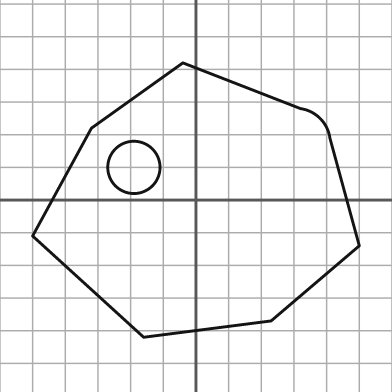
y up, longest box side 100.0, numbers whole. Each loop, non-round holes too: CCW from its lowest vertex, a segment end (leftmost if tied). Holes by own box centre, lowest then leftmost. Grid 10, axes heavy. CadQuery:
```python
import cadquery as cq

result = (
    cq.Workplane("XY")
    .moveTo(-16.0, -42.0)
    .lineTo(23.0, -37.0)
    .lineTo(50.0, -14.0)
    .lineTo(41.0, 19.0)
    .threePointArc((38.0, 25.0), (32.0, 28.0))
    .lineTo(-4.0, 42.0)
    .lineTo(-32.0, 22.0)
    .lineTo(-50.0, -11.0)
    .close()
    .moveTo(-19.0, 10.0)
    .circle(8.0)
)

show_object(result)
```